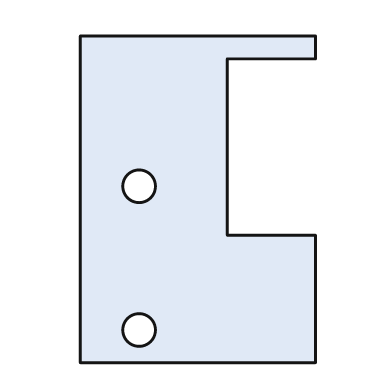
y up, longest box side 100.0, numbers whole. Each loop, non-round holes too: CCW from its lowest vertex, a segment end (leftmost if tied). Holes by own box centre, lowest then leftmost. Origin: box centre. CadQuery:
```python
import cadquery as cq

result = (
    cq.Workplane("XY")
    .moveTo(-36.0, -50.0)
    .lineTo(36.0, -50.0)
    .lineTo(36.0, -11.0)
    .lineTo(9.0, -11.0)
    .lineTo(9.0, 43.0)
    .lineTo(36.0, 43.0)
    .lineTo(36.0, 50.0)
    .lineTo(-36.0, 50.0)
    .close()
    .moveTo(-18.0, -40.0)
    .circle(5.0)
    .moveTo(-18.0, 4.0)
    .circle(5.0)
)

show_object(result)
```